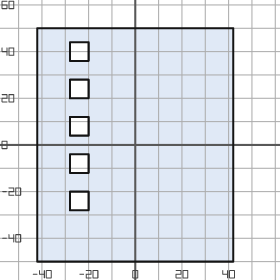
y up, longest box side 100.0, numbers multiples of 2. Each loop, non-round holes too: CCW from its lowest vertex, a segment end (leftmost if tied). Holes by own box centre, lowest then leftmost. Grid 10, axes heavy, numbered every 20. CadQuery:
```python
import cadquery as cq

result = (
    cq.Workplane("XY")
    .moveTo(-42.0, -50.0)
    .lineTo(42.0, -50.0)
    .lineTo(42.0, 50.0)
    .lineTo(-42.0, 50.0)
    .close()
    .moveTo(-28.0, -28.0)
    .lineTo(-20.0, -28.0)
    .lineTo(-20.0, -20.0)
    .lineTo(-28.0, -20.0)
    .close()
    .moveTo(-28.0, -12.0)
    .lineTo(-20.0, -12.0)
    .lineTo(-20.0, -4.0)
    .lineTo(-28.0, -4.0)
    .close()
    .moveTo(-28.0, 4.0)
    .lineTo(-20.0, 4.0)
    .lineTo(-20.0, 12.0)
    .lineTo(-28.0, 12.0)
    .close()
    .moveTo(-28.0, 20.0)
    .lineTo(-20.0, 20.0)
    .lineTo(-20.0, 28.0)
    .lineTo(-28.0, 28.0)
    .close()
    .moveTo(-28.0, 36.0)
    .lineTo(-20.0, 36.0)
    .lineTo(-20.0, 44.0)
    .lineTo(-28.0, 44.0)
    .close()
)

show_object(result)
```